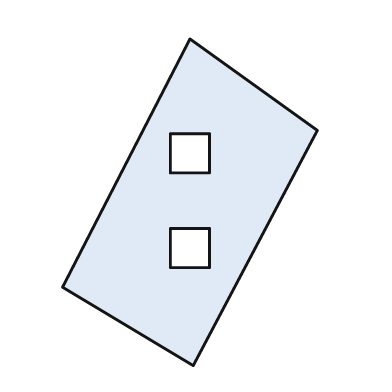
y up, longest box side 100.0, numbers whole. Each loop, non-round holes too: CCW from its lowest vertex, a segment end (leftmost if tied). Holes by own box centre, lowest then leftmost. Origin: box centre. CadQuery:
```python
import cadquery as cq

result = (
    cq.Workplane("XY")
    .moveTo(1.0, -50.0)
    .lineTo(39.0, 22.0)
    .lineTo(0.0, 50.0)
    .lineTo(-39.0, -26.0)
    .close()
    .moveTo(-6.0, -20.0)
    .lineTo(6.0, -20.0)
    .lineTo(6.0, -8.0)
    .lineTo(-6.0, -8.0)
    .close()
    .moveTo(-6.0, 9.0)
    .lineTo(6.0, 9.0)
    .lineTo(6.0, 21.0)
    .lineTo(-6.0, 21.0)
    .close()
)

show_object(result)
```